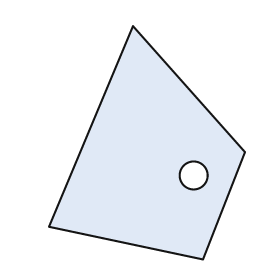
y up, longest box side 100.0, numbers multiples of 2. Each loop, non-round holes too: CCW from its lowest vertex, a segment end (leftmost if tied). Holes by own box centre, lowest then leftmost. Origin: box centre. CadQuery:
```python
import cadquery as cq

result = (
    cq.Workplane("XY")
    .moveTo(24.0, -50.0)
    .lineTo(42.0, -4.0)
    .lineTo(-6.0, 50.0)
    .lineTo(-42.0, -36.0)
    .close()
    .moveTo(20.0, -14.0)
    .circle(6.0)
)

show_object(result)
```